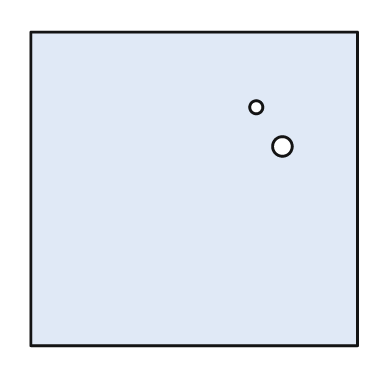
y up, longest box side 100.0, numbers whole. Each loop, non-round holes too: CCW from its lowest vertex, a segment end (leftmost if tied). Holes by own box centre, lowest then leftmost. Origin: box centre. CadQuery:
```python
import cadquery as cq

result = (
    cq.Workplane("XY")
    .moveTo(-50.0, -48.0)
    .lineTo(50.0, -48.0)
    .lineTo(50.0, 48.0)
    .lineTo(-50.0, 48.0)
    .close()
    .moveTo(27.0, 13.0)
    .circle(3.0)
    .moveTo(19.0, 25.0)
    .circle(2.0)
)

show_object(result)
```